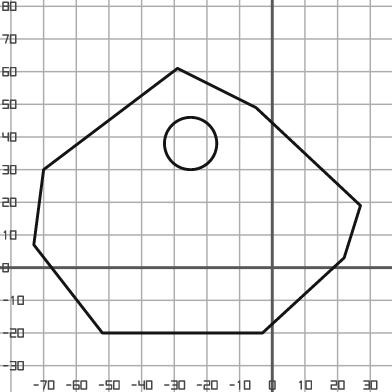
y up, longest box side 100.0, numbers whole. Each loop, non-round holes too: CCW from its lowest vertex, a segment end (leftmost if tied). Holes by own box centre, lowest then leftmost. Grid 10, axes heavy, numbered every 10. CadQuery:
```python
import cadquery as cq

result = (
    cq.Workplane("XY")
    .moveTo(-52.0, -20.0)
    .lineTo(-3.0, -20.0)
    .lineTo(22.0, 3.0)
    .lineTo(27.0, 19.0)
    .lineTo(-5.0, 49.0)
    .lineTo(-29.0, 61.0)
    .lineTo(-70.0, 30.0)
    .lineTo(-73.0, 7.0)
    .close()
    .moveTo(-25.0, 38.0)
    .circle(8.0)
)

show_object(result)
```